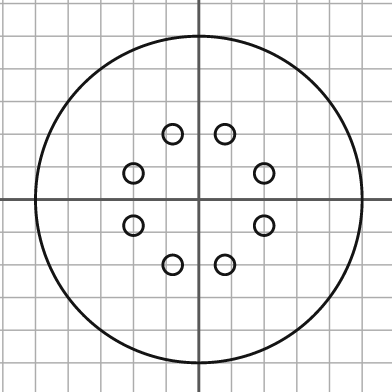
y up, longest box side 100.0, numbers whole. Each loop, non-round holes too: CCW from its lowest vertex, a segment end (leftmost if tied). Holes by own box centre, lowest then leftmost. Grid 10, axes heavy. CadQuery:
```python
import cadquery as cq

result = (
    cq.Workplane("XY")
    .moveTo(0.0, 0.0)
    .circle(50.0)
    .moveTo(-8.0, -20.0)
    .circle(3.0)
    .moveTo(8.0, -20.0)
    .circle(3.0)
    .moveTo(-20.0, -8.0)
    .circle(3.0)
    .moveTo(20.0, -8.0)
    .circle(3.0)
    .moveTo(-20.0, 8.0)
    .circle(3.0)
    .moveTo(20.0, 8.0)
    .circle(3.0)
    .moveTo(-8.0, 20.0)
    .circle(3.0)
    .moveTo(8.0, 20.0)
    .circle(3.0)
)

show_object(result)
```